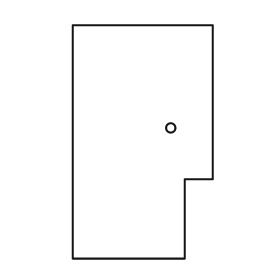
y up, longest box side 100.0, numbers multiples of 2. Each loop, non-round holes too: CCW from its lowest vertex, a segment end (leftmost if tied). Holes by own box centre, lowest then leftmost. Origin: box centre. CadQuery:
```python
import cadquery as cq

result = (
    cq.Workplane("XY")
    .moveTo(-30.0, -50.0)
    .lineTo(18.0, -50.0)
    .lineTo(18.0, -16.0)
    .lineTo(30.0, -16.0)
    .lineTo(30.0, 50.0)
    .lineTo(-30.0, 50.0)
    .close()
    .moveTo(12.0, 6.0)
    .circle(2.0)
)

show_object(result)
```